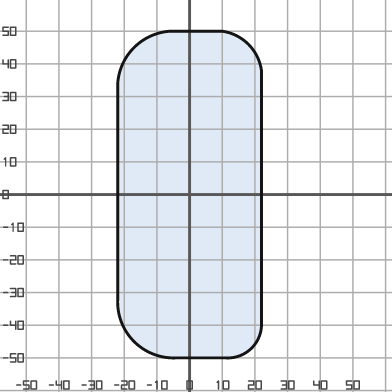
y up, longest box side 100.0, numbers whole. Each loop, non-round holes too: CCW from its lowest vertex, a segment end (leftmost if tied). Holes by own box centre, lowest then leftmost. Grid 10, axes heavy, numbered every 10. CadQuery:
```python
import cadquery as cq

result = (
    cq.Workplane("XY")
    .moveTo(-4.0, -50.0)
    .lineTo(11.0, -50.0)
    .threePointArc((19.0, -47.0), (22.0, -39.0))
    .lineTo(22.0, 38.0)
    .threePointArc((18.0, 46.0), (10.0, 50.0))
    .lineTo(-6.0, 50.0)
    .threePointArc((-17.0, 45.0), (-22.0, 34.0))
    .lineTo(-22.0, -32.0)
    .threePointArc((-17.0, -45.0), (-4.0, -50.0))
    .close()
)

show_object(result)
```